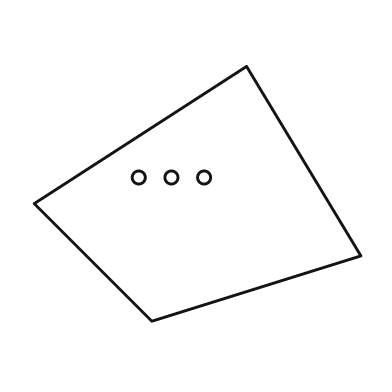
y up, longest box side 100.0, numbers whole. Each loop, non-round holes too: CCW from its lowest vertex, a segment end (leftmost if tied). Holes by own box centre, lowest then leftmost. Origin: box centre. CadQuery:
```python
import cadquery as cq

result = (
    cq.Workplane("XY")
    .moveTo(-14.0, -39.0)
    .lineTo(50.0, -19.0)
    .lineTo(15.0, 39.0)
    .lineTo(-50.0, -3.0)
    .close()
    .moveTo(-18.0, 5.0)
    .circle(2.0)
    .moveTo(-8.0, 5.0)
    .circle(2.0)
    .moveTo(2.0, 5.0)
    .circle(2.0)
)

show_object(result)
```